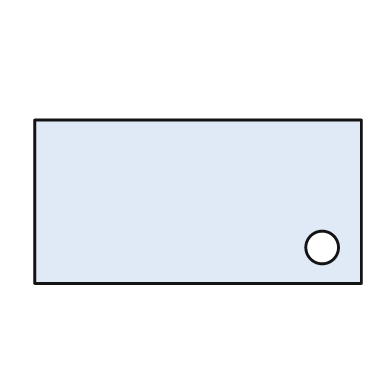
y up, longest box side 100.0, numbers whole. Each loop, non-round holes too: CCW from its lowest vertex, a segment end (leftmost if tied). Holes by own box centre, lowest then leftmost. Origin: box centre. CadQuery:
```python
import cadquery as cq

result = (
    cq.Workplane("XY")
    .moveTo(-50.0, -25.0)
    .lineTo(50.0, -25.0)
    .lineTo(50.0, 25.0)
    .lineTo(-50.0, 25.0)
    .close()
    .moveTo(38.0, -14.0)
    .circle(5.0)
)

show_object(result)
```